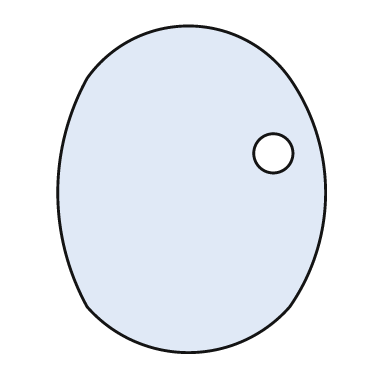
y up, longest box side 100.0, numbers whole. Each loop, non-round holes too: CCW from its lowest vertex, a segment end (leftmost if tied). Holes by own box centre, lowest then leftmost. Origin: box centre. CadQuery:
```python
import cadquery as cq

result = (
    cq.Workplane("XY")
    .moveTo(-32.0, -36.0)
    .threePointArc((-1.0, -50.0), (30.0, -36.0))
    .threePointArc((41.0, -1.0), (30.0, 34.0))
    .threePointArc((-1.0, 50.0), (-32.0, 34.0))
    .threePointArc((-41.0, -1.0), (-32.0, -36.0))
    .close()
    .moveTo(25.0, 11.0)
    .circle(6.0)
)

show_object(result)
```